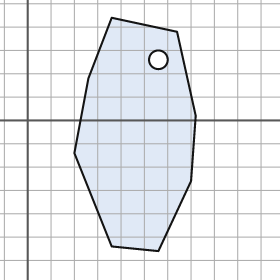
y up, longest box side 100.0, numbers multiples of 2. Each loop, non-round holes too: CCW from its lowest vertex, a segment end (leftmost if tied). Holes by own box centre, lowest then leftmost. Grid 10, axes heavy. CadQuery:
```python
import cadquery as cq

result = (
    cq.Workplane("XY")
    .moveTo(56.0, -56.0)
    .lineTo(70.0, -26.0)
    .lineTo(72.0, 2.0)
    .lineTo(64.0, 38.0)
    .lineTo(36.0, 44.0)
    .lineTo(26.0, 18.0)
    .lineTo(20.0, -14.0)
    .lineTo(36.0, -54.0)
    .close()
    .moveTo(56.0, 26.0)
    .circle(4.0)
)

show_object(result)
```